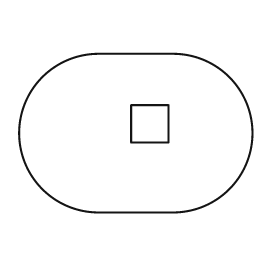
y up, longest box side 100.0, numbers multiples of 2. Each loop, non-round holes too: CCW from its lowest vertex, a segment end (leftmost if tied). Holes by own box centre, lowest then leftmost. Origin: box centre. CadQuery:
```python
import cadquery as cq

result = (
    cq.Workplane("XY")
    .moveTo(-16.0, -34.0)
    .lineTo(16.0, -34.0)
    .threePointArc((50.0, 0.0), (16.0, 34.0))
    .lineTo(-16.0, 34.0)
    .threePointArc((-50.0, 0.0), (-16.0, -34.0))
    .close()
    .moveTo(-2.0, -4.0)
    .lineTo(14.0, -4.0)
    .lineTo(14.0, 12.0)
    .lineTo(-2.0, 12.0)
    .close()
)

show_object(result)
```